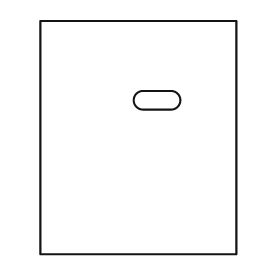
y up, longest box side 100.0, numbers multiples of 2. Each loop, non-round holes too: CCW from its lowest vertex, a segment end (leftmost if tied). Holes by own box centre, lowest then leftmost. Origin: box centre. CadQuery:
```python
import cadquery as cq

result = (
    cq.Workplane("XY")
    .moveTo(-42.0, -50.0)
    .lineTo(42.0, -50.0)
    .lineTo(42.0, 50.0)
    .lineTo(-42.0, 50.0)
    .close()
    .moveTo(2.0, 12.0)
    .lineTo(14.0, 12.0)
    .threePointArc((18.0, 16.0), (14.0, 20.0))
    .lineTo(2.0, 20.0)
    .threePointArc((-2.0, 16.0), (2.0, 12.0))
    .close()
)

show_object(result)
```